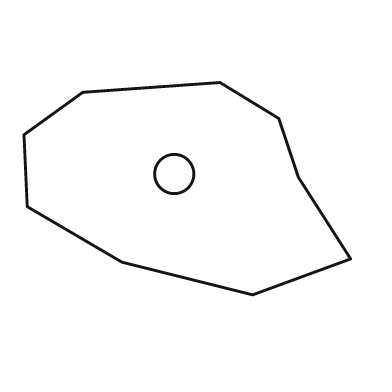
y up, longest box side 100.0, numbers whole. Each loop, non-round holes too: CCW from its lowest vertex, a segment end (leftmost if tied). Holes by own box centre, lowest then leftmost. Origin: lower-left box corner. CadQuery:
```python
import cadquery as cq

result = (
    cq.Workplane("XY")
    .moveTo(70.0, 0.0)
    .lineTo(100.0, 11.0)
    .lineTo(84.0, 36.0)
    .lineTo(78.0, 54.0)
    .lineTo(60.0, 65.0)
    .lineTo(18.0, 62.0)
    .lineTo(0.0, 49.0)
    .lineTo(1.0, 27.0)
    .lineTo(30.0, 10.0)
    .close()
    .moveTo(46.0, 37.0)
    .circle(6.0)
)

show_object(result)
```